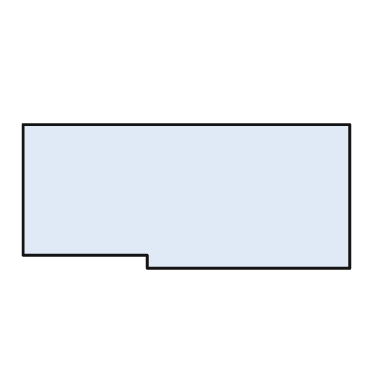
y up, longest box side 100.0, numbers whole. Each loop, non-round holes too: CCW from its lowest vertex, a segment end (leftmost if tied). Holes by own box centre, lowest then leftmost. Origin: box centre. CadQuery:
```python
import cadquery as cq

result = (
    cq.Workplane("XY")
    .moveTo(-12.0, -22.0)
    .lineTo(50.0, -22.0)
    .lineTo(50.0, 22.0)
    .lineTo(-50.0, 22.0)
    .lineTo(-50.0, -18.0)
    .lineTo(-12.0, -18.0)
    .close()
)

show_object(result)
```